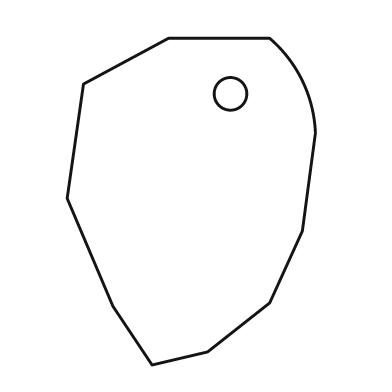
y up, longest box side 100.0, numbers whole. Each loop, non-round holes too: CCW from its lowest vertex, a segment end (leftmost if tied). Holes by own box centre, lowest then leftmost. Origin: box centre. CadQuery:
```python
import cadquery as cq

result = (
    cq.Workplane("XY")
    .moveTo(-12.0, -50.0)
    .lineTo(5.0, -46.0)
    .lineTo(24.0, -31.0)
    .lineTo(34.0, -9.0)
    .lineTo(38.0, 21.0)
    .threePointArc((34.0, 37.0), (24.0, 50.0))
    .lineTo(-7.0, 50.0)
    .lineTo(-33.0, 36.0)
    .lineTo(-38.0, 1.0)
    .lineTo(-24.0, -32.0)
    .close()
    .moveTo(12.0, 33.0)
    .circle(5.0)
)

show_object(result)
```